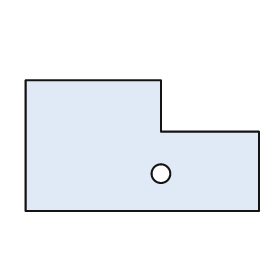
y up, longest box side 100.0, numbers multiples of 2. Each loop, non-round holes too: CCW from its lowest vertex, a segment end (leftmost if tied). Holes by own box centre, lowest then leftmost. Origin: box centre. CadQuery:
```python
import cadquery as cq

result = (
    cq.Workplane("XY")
    .moveTo(-50.0, -28.0)
    .lineTo(50.0, -28.0)
    .lineTo(50.0, 6.0)
    .lineTo(8.0, 6.0)
    .lineTo(8.0, 28.0)
    .lineTo(-50.0, 28.0)
    .close()
    .moveTo(8.0, -12.0)
    .circle(4.0)
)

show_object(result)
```